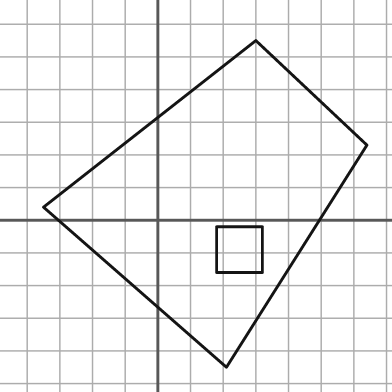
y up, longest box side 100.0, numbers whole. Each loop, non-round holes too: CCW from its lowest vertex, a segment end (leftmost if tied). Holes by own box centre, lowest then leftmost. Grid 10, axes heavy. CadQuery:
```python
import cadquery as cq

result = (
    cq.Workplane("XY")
    .moveTo(21.0, -45.0)
    .lineTo(64.0, 23.0)
    .lineTo(30.0, 55.0)
    .lineTo(-35.0, 4.0)
    .close()
    .moveTo(18.0, -16.0)
    .lineTo(32.0, -16.0)
    .lineTo(32.0, -2.0)
    .lineTo(18.0, -2.0)
    .close()
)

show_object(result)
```